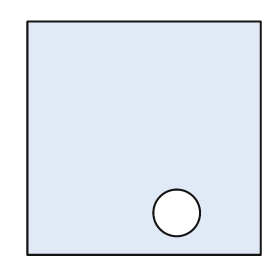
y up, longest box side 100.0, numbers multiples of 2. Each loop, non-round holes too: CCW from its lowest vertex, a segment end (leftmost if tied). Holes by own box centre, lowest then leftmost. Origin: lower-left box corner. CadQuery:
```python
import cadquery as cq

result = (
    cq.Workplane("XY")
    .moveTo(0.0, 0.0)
    .lineTo(100.0, 0.0)
    .lineTo(100.0, 100.0)
    .lineTo(0.0, 100.0)
    .close()
    .moveTo(64.0, 18.0)
    .circle(10.0)
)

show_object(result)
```